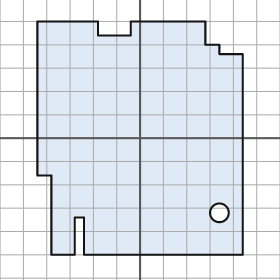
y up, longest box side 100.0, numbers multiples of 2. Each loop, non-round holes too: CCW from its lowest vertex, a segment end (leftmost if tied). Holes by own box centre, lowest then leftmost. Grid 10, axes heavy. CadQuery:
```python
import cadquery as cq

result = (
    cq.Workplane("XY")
    .moveTo(-38.0, -50.0)
    .lineTo(-28.0, -50.0)
    .lineTo(-28.0, -34.0)
    .lineTo(-24.0, -34.0)
    .lineTo(-24.0, -50.0)
    .lineTo(44.0, -50.0)
    .lineTo(44.0, 36.0)
    .lineTo(34.0, 36.0)
    .lineTo(34.0, 40.0)
    .lineTo(28.0, 40.0)
    .lineTo(28.0, 50.0)
    .lineTo(-4.0, 50.0)
    .lineTo(-4.0, 44.0)
    .lineTo(-18.0, 44.0)
    .lineTo(-18.0, 50.0)
    .lineTo(-44.0, 50.0)
    .lineTo(-44.0, -16.0)
    .lineTo(-38.0, -16.0)
    .close()
    .moveTo(34.0, -32.0)
    .circle(4.0)
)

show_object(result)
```